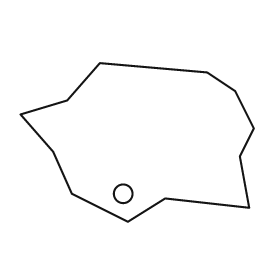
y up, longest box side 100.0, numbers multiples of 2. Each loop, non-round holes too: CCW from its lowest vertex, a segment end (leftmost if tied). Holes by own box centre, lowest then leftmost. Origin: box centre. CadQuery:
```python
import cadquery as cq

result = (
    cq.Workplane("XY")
    .moveTo(-4.0, -34.0)
    .lineTo(12.0, -24.0)
    .lineTo(48.0, -28.0)
    .lineTo(44.0, -6.0)
    .lineTo(50.0, 6.0)
    .lineTo(42.0, 22.0)
    .lineTo(30.0, 30.0)
    .lineTo(-16.0, 34.0)
    .lineTo(-30.0, 18.0)
    .lineTo(-50.0, 12.0)
    .lineTo(-36.0, -4.0)
    .lineTo(-28.0, -22.0)
    .close()
    .moveTo(-6.0, -22.0)
    .circle(4.0)
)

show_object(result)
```